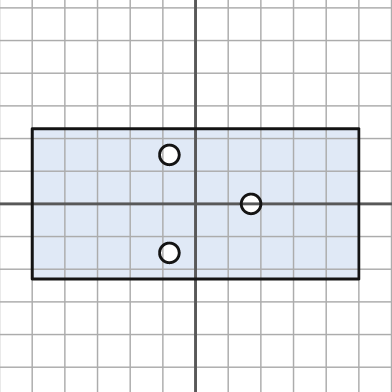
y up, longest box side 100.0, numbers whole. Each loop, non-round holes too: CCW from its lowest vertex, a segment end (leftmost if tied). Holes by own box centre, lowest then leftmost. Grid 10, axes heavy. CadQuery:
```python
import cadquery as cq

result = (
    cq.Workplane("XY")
    .moveTo(-50.0, -23.0)
    .lineTo(50.0, -23.0)
    .lineTo(50.0, 23.0)
    .lineTo(-50.0, 23.0)
    .close()
    .moveTo(-8.0, -15.0)
    .circle(3.0)
    .moveTo(17.0, 0.0)
    .circle(3.0)
    .moveTo(-8.0, 15.0)
    .circle(3.0)
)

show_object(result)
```